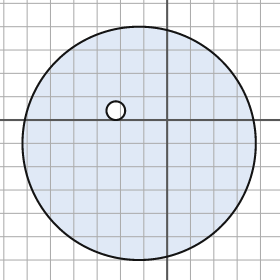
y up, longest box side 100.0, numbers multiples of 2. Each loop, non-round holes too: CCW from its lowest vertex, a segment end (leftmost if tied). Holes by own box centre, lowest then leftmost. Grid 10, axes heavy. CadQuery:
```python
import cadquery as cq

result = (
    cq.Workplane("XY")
    .moveTo(-12.0, -10.0)
    .circle(50.0)
    .moveTo(-22.0, 4.0)
    .circle(4.0)
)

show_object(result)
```